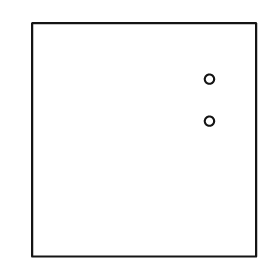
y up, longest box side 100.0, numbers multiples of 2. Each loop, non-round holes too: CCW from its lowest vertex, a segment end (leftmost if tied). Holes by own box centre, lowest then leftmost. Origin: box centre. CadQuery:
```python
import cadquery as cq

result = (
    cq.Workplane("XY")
    .moveTo(-48.0, -50.0)
    .lineTo(48.0, -50.0)
    .lineTo(48.0, 50.0)
    .lineTo(-48.0, 50.0)
    .close()
    .moveTo(28.0, 8.0)
    .circle(2.0)
    .moveTo(28.0, 26.0)
    .circle(2.0)
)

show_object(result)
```